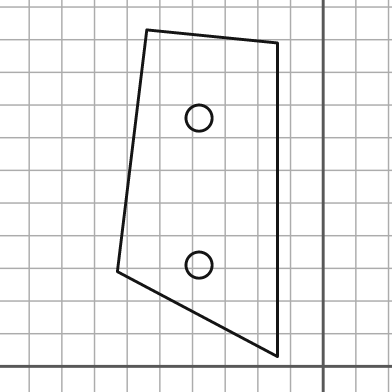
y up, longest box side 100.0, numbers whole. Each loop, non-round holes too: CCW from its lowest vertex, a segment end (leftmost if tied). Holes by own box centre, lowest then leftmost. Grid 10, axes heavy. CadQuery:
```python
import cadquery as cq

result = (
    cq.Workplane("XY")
    .moveTo(-14.0, 3.0)
    .lineTo(-14.0, 99.0)
    .lineTo(-54.0, 103.0)
    .lineTo(-63.0, 29.0)
    .close()
    .moveTo(-38.0, 31.0)
    .circle(4.0)
    .moveTo(-38.0, 76.0)
    .circle(4.0)
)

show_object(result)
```